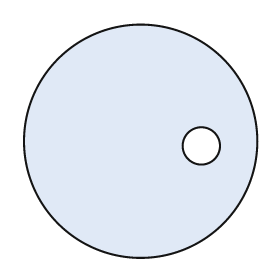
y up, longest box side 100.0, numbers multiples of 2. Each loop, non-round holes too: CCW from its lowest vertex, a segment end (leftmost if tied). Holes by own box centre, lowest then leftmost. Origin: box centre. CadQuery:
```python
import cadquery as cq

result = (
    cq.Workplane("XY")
    .moveTo(0.0, 0.0)
    .circle(50.0)
    .moveTo(26.0, -2.0)
    .circle(8.0)
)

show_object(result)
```